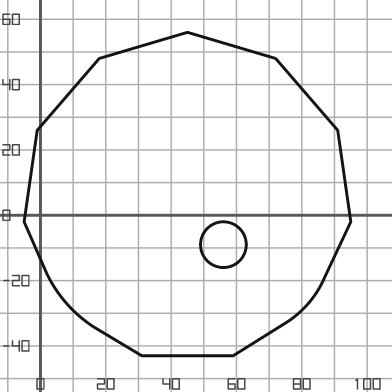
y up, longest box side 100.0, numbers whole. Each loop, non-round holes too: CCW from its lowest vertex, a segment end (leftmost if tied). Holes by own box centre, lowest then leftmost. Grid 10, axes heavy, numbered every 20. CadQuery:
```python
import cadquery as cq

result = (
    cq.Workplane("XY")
    .moveTo(31.0, -43.0)
    .lineTo(59.0, -43.0)
    .lineTo(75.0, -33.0)
    .threePointArc((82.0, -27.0), (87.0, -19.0))
    .lineTo(95.0, -2.0)
    .lineTo(91.0, 26.0)
    .lineTo(72.0, 48.0)
    .lineTo(45.0, 56.0)
    .lineTo(18.0, 48.0)
    .lineTo(-1.0, 26.0)
    .lineTo(-5.0, -2.0)
    .lineTo(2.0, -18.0)
    .threePointArc((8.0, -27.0), (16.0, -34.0))
    .close()
    .moveTo(56.0, -9.0)
    .circle(7.0)
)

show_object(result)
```